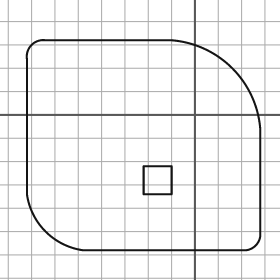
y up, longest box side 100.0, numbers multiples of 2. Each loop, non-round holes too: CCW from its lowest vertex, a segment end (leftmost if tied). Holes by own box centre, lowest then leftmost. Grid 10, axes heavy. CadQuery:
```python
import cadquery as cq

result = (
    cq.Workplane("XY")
    .moveTo(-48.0, -58.0)
    .lineTo(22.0, -58.0)
    .threePointArc((26.0, -56.0), (28.0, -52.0))
    .lineTo(28.0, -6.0)
    .threePointArc((16.0, 20.0), (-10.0, 32.0))
    .lineTo(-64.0, 32.0)
    .threePointArc((-70.0, 30.0), (-72.0, 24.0))
    .lineTo(-72.0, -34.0)
    .threePointArc((-64.0, -50.0), (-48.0, -58.0))
    .close()
    .moveTo(-22.0, -34.0)
    .lineTo(-10.0, -34.0)
    .lineTo(-10.0, -22.0)
    .lineTo(-22.0, -22.0)
    .close()
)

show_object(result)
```